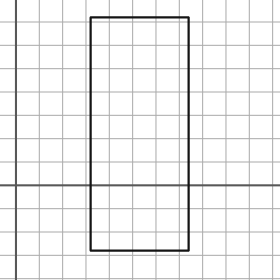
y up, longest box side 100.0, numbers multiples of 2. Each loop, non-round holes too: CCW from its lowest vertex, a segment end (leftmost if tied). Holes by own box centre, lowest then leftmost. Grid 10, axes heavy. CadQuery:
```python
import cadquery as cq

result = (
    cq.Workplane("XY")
    .moveTo(32.0, -28.0)
    .lineTo(74.0, -28.0)
    .lineTo(74.0, 72.0)
    .lineTo(32.0, 72.0)
    .close()
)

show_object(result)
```